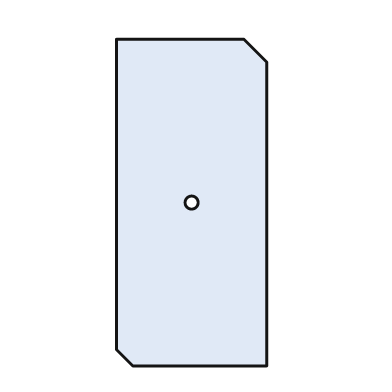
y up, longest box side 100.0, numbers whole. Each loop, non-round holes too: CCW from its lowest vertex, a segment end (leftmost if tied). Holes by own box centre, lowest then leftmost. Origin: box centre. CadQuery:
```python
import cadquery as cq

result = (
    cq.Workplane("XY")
    .moveTo(-18.0, -50.0)
    .lineTo(23.0, -50.0)
    .lineTo(23.0, 43.0)
    .lineTo(16.0, 50.0)
    .lineTo(-23.0, 50.0)
    .lineTo(-23.0, -45.0)
    .close()
    .moveTo(0.0, 0.0)
    .circle(2.0)
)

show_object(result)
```